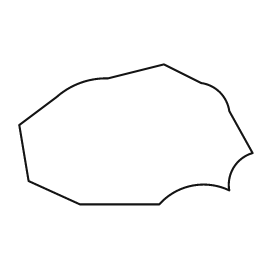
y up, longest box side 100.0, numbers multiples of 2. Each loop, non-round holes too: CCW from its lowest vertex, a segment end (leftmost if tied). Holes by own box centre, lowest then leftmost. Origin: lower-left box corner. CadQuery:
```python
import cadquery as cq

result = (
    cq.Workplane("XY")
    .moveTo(26.0, 0.0)
    .lineTo(60.0, 0.0)
    .threePointArc((74.0, 8.0), (90.0, 6.0))
    .threePointArc((92.0, 16.0), (100.0, 22.0))
    .lineTo(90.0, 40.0)
    .threePointArc((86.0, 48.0), (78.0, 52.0))
    .lineTo(62.0, 60.0)
    .lineTo(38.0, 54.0)
    .threePointArc((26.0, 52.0), (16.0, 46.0))
    .lineTo(0.0, 34.0)
    .lineTo(4.0, 10.0)
    .close()
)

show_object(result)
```